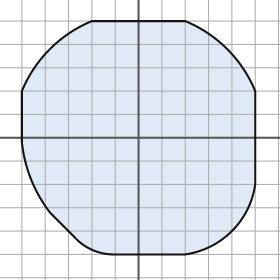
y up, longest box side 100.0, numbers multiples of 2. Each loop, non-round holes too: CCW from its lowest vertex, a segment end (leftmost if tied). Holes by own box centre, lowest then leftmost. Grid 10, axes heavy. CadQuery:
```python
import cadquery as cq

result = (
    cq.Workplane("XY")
    .moveTo(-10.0, -50.0)
    .lineTo(20.0, -50.0)
    .threePointArc((40.0, -40.0), (50.0, -20.0))
    .lineTo(50.0, 20.0)
    .threePointArc((38.0, 38.0), (20.0, 50.0))
    .lineTo(-20.0, 50.0)
    .threePointArc((-38.0, 38.0), (-50.0, 20.0))
    .lineTo(-50.0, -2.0)
    .threePointArc((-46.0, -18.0), (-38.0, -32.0))
    .lineTo(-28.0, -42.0)
    .threePointArc((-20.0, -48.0), (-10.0, -50.0))
    .close()
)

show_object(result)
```